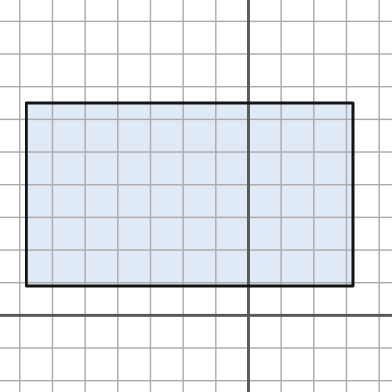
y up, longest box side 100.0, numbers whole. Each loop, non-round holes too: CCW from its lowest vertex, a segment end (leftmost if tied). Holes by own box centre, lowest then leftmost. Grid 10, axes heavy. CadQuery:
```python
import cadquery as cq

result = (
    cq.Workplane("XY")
    .moveTo(-68.0, 9.0)
    .lineTo(32.0, 9.0)
    .lineTo(32.0, 65.0)
    .lineTo(-68.0, 65.0)
    .close()
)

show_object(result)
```